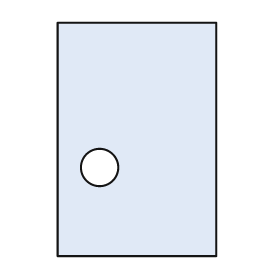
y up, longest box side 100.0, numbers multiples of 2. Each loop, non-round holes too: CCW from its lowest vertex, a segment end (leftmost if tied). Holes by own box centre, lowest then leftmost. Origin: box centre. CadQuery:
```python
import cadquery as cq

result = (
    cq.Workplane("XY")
    .moveTo(-34.0, -50.0)
    .lineTo(34.0, -50.0)
    .lineTo(34.0, 50.0)
    .lineTo(-34.0, 50.0)
    .close()
    .moveTo(-16.0, -12.0)
    .circle(8.0)
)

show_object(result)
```